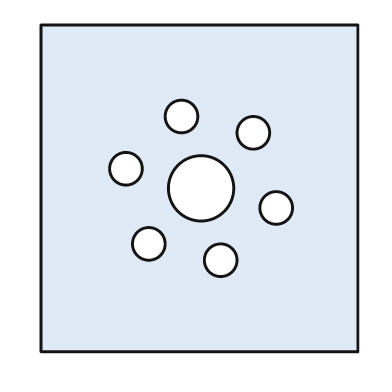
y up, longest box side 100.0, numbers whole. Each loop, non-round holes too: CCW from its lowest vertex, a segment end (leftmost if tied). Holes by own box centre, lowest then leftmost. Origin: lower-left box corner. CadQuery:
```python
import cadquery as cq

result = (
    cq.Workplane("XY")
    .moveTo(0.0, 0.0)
    .lineTo(97.0, 0.0)
    .lineTo(97.0, 100.0)
    .lineTo(0.0, 100.0)
    .close()
    .moveTo(55.0, 28.0)
    .circle(5.0)
    .moveTo(33.0, 33.0)
    .circle(5.0)
    .moveTo(72.0, 44.0)
    .circle(5.0)
    .moveTo(49.0, 50.0)
    .circle(10.0)
    .moveTo(26.0, 56.0)
    .circle(5.0)
    .moveTo(65.0, 67.0)
    .circle(5.0)
    .moveTo(43.0, 72.0)
    .circle(5.0)
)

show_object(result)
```